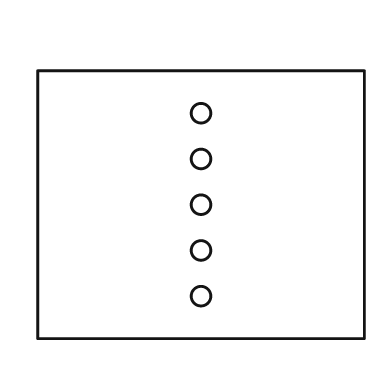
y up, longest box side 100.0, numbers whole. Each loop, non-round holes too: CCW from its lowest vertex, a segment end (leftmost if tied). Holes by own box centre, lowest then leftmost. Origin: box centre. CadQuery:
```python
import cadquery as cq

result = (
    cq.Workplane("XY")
    .moveTo(-50.0, -41.0)
    .lineTo(50.0, -41.0)
    .lineTo(50.0, 41.0)
    .lineTo(-50.0, 41.0)
    .close()
    .moveTo(0.0, -28.0)
    .circle(3.0)
    .moveTo(0.0, -14.0)
    .circle(3.0)
    .moveTo(0.0, 0.0)
    .circle(3.0)
    .moveTo(0.0, 14.0)
    .circle(3.0)
    .moveTo(0.0, 28.0)
    .circle(3.0)
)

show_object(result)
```